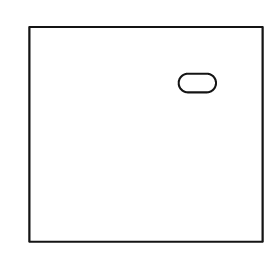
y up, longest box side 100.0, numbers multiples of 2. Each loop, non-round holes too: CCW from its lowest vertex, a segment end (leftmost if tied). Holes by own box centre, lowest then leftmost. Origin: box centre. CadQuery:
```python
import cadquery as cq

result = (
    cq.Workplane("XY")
    .moveTo(-50.0, -46.0)
    .lineTo(50.0, -46.0)
    .lineTo(50.0, 46.0)
    .lineTo(-50.0, 46.0)
    .close()
    .moveTo(18.0, 18.0)
    .lineTo(26.0, 18.0)
    .threePointArc((30.0, 22.0), (26.0, 26.0))
    .lineTo(18.0, 26.0)
    .threePointArc((14.0, 22.0), (18.0, 18.0))
    .close()
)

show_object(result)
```